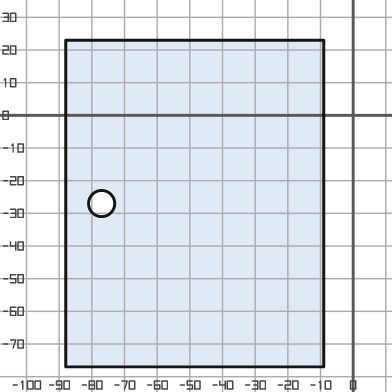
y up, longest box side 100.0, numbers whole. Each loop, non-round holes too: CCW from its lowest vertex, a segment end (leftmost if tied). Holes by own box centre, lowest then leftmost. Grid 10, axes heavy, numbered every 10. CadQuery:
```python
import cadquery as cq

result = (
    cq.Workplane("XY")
    .moveTo(-88.0, -77.0)
    .lineTo(-9.0, -77.0)
    .lineTo(-9.0, 23.0)
    .lineTo(-88.0, 23.0)
    .close()
    .moveTo(-77.0, -27.0)
    .circle(4.0)
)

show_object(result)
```